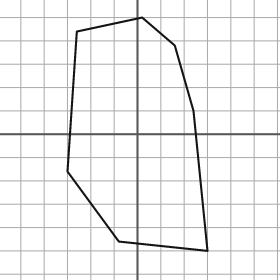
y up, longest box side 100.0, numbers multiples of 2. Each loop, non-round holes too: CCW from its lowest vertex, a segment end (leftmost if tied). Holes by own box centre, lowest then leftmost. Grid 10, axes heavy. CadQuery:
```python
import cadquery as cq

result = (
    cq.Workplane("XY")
    .moveTo(30.0, -50.0)
    .lineTo(24.0, 10.0)
    .lineTo(16.0, 38.0)
    .lineTo(2.0, 50.0)
    .lineTo(-26.0, 44.0)
    .lineTo(-30.0, -16.0)
    .lineTo(-8.0, -46.0)
    .close()
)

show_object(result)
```